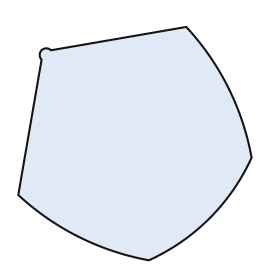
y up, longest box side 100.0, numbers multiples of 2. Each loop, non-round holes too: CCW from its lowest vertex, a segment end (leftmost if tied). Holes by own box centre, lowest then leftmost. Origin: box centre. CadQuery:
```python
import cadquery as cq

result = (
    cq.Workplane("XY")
    .moveTo(6.0, -50.0)
    .threePointArc((32.0, -32.0), (50.0, -6.0))
    .threePointArc((40.0, 24.0), (22.0, 50.0))
    .lineTo(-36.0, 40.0)
    .threePointArc((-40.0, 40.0), (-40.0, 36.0))
    .lineTo(-50.0, -22.0)
    .threePointArc((-24.0, -40.0), (6.0, -50.0))
    .close()
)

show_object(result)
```